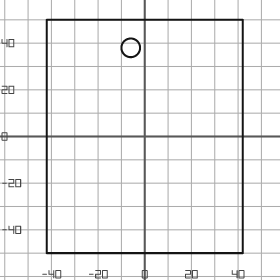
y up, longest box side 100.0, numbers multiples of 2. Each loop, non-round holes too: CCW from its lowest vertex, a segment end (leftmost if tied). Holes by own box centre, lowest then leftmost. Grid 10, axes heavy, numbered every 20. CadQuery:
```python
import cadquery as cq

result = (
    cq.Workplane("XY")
    .moveTo(-42.0, -50.0)
    .lineTo(42.0, -50.0)
    .lineTo(42.0, 50.0)
    .lineTo(-42.0, 50.0)
    .close()
    .moveTo(-6.0, 38.0)
    .circle(4.0)
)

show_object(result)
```